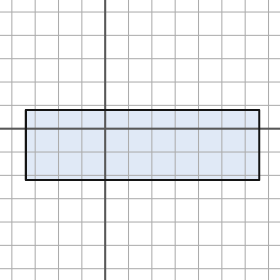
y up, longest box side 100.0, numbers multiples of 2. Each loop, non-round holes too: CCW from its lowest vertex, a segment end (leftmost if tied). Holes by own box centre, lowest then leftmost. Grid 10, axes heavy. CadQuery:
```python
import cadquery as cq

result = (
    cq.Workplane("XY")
    .moveTo(-34.0, -22.0)
    .lineTo(66.0, -22.0)
    .lineTo(66.0, 8.0)
    .lineTo(-34.0, 8.0)
    .close()
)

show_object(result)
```